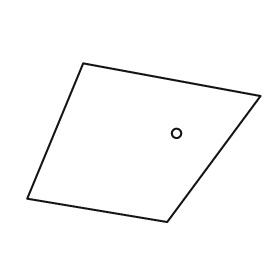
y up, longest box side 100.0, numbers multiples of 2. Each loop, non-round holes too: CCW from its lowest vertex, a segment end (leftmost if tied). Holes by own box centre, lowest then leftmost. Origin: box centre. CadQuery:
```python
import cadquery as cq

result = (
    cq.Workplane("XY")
    .moveTo(10.0, -34.0)
    .lineTo(50.0, 20.0)
    .lineTo(-26.0, 34.0)
    .lineTo(-50.0, -24.0)
    .close()
    .moveTo(14.0, 4.0)
    .circle(2.0)
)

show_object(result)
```